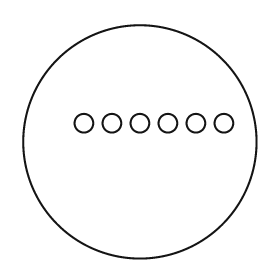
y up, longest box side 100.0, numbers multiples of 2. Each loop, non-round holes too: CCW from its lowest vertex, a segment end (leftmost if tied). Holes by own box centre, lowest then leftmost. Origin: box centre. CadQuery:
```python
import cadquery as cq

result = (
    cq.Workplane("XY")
    .moveTo(0.0, 0.0)
    .circle(50.0)
    .moveTo(-24.0, 8.0)
    .circle(4.0)
    .moveTo(-12.0, 8.0)
    .circle(4.0)
    .moveTo(0.0, 8.0)
    .circle(4.0)
    .moveTo(12.0, 8.0)
    .circle(4.0)
    .moveTo(24.0, 8.0)
    .circle(4.0)
    .moveTo(36.0, 8.0)
    .circle(4.0)
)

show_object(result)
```